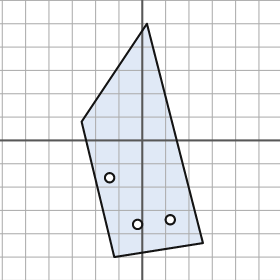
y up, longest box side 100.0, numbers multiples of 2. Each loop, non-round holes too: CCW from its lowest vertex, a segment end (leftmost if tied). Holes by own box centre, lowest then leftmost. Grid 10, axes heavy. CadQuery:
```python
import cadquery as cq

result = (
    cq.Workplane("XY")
    .moveTo(-12.0, -50.0)
    .lineTo(26.0, -44.0)
    .lineTo(2.0, 50.0)
    .lineTo(-26.0, 8.0)
    .close()
    .moveTo(-2.0, -36.0)
    .circle(2.0)
    .moveTo(12.0, -34.0)
    .circle(2.0)
    .moveTo(-14.0, -16.0)
    .circle(2.0)
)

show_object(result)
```